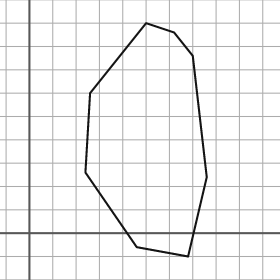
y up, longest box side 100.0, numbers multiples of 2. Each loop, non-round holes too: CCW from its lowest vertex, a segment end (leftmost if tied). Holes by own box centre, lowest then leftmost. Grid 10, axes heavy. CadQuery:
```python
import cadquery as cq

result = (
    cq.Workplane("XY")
    .moveTo(68.0, -10.0)
    .lineTo(76.0, 24.0)
    .lineTo(70.0, 76.0)
    .lineTo(62.0, 86.0)
    .lineTo(50.0, 90.0)
    .lineTo(26.0, 60.0)
    .lineTo(24.0, 26.0)
    .lineTo(46.0, -6.0)
    .close()
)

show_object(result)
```